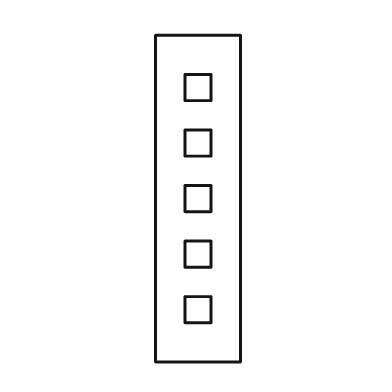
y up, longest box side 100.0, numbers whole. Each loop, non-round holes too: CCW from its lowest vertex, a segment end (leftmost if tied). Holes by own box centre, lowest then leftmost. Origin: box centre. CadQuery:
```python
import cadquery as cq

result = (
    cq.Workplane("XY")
    .moveTo(-13.0, -50.0)
    .lineTo(13.0, -50.0)
    .lineTo(13.0, 50.0)
    .lineTo(-13.0, 50.0)
    .close()
    .moveTo(-4.0, -38.0)
    .lineTo(4.0, -38.0)
    .lineTo(4.0, -30.0)
    .lineTo(-4.0, -30.0)
    .close()
    .moveTo(-4.0, -21.0)
    .lineTo(4.0, -21.0)
    .lineTo(4.0, -13.0)
    .lineTo(-4.0, -13.0)
    .close()
    .moveTo(-4.0, -4.0)
    .lineTo(4.0, -4.0)
    .lineTo(4.0, 4.0)
    .lineTo(-4.0, 4.0)
    .close()
    .moveTo(-4.0, 13.0)
    .lineTo(4.0, 13.0)
    .lineTo(4.0, 21.0)
    .lineTo(-4.0, 21.0)
    .close()
    .moveTo(-4.0, 30.0)
    .lineTo(4.0, 30.0)
    .lineTo(4.0, 38.0)
    .lineTo(-4.0, 38.0)
    .close()
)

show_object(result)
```